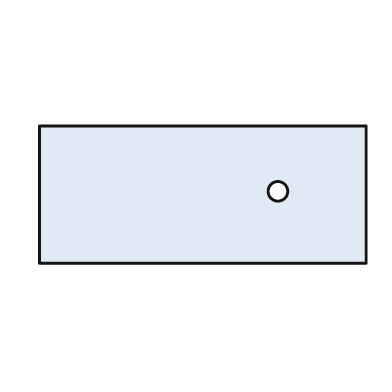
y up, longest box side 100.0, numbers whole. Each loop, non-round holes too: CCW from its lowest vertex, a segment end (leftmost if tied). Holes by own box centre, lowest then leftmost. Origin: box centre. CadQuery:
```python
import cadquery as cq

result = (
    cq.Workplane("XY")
    .moveTo(-50.0, -21.0)
    .lineTo(50.0, -21.0)
    .lineTo(50.0, 21.0)
    .lineTo(-50.0, 21.0)
    .close()
    .moveTo(23.0, 1.0)
    .circle(3.0)
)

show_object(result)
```